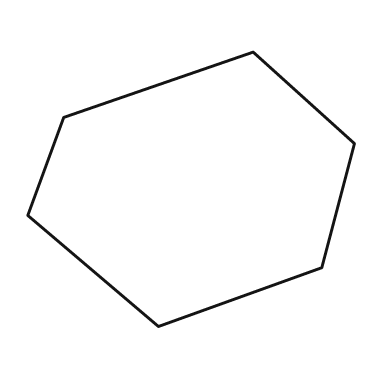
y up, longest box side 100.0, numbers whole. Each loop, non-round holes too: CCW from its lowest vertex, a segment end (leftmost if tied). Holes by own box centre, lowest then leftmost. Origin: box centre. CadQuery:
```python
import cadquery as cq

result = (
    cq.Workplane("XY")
    .moveTo(-10.0, -42.0)
    .lineTo(40.0, -24.0)
    .lineTo(50.0, 14.0)
    .lineTo(19.0, 42.0)
    .lineTo(-39.0, 22.0)
    .lineTo(-50.0, -8.0)
    .close()
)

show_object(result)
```